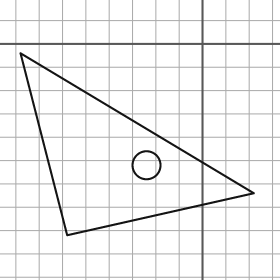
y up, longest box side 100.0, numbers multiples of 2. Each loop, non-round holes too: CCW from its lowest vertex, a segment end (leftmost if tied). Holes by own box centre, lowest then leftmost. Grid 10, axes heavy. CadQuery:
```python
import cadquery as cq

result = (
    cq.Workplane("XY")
    .moveTo(-58.0, -82.0)
    .lineTo(22.0, -64.0)
    .lineTo(-78.0, -4.0)
    .close()
    .moveTo(-24.0, -52.0)
    .circle(6.0)
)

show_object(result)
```